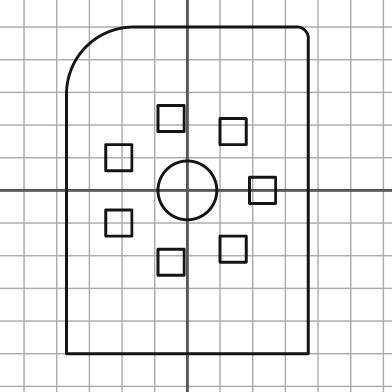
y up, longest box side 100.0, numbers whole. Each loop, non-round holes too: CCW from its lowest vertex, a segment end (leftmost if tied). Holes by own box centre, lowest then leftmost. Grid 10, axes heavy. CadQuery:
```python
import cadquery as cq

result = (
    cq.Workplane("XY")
    .moveTo(-37.0, -50.0)
    .lineTo(37.0, -50.0)
    .lineTo(37.0, 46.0)
    .threePointArc((36.0, 49.0), (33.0, 50.0))
    .lineTo(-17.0, 50.0)
    .threePointArc((-31.0, 44.0), (-37.0, 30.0))
    .close()
    .moveTo(-9.0, -26.0)
    .lineTo(-1.0, -26.0)
    .lineTo(-1.0, -18.0)
    .lineTo(-9.0, -18.0)
    .close()
    .moveTo(10.0, -22.0)
    .lineTo(18.0, -22.0)
    .lineTo(18.0, -14.0)
    .lineTo(10.0, -14.0)
    .close()
    .moveTo(-25.0, -14.0)
    .lineTo(-17.0, -14.0)
    .lineTo(-17.0, -6.0)
    .lineTo(-25.0, -6.0)
    .close()
    .moveTo(0.0, 0.0)
    .circle(9.0)
    .moveTo(19.0, -4.0)
    .lineTo(27.0, -4.0)
    .lineTo(27.0, 4.0)
    .lineTo(19.0, 4.0)
    .close()
    .moveTo(-25.0, 6.0)
    .lineTo(-17.0, 6.0)
    .lineTo(-17.0, 14.0)
    .lineTo(-25.0, 14.0)
    .close()
    .moveTo(10.0, 14.0)
    .lineTo(18.0, 14.0)
    .lineTo(18.0, 22.0)
    .lineTo(10.0, 22.0)
    .close()
    .moveTo(-9.0, 18.0)
    .lineTo(-1.0, 18.0)
    .lineTo(-1.0, 26.0)
    .lineTo(-9.0, 26.0)
    .close()
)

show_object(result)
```